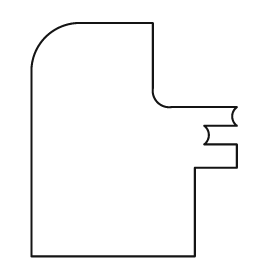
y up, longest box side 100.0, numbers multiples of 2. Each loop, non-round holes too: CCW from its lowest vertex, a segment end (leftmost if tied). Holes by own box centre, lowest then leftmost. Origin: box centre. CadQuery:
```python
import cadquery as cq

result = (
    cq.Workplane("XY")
    .moveTo(-44.0, -50.0)
    .lineTo(26.0, -50.0)
    .lineTo(26.0, -12.0)
    .lineTo(44.0, -12.0)
    .lineTo(44.0, -2.0)
    .lineTo(30.0, -2.0)
    .threePointArc((32.0, 2.0), (30.0, 6.0))
    .lineTo(44.0, 6.0)
    .threePointArc((42.0, 10.0), (44.0, 14.0))
    .lineTo(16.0, 14.0)
    .threePointArc((10.0, 16.0), (8.0, 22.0))
    .lineTo(8.0, 50.0)
    .lineTo(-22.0, 50.0)
    .threePointArc((-38.0, 44.0), (-44.0, 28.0))
    .close()
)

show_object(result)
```